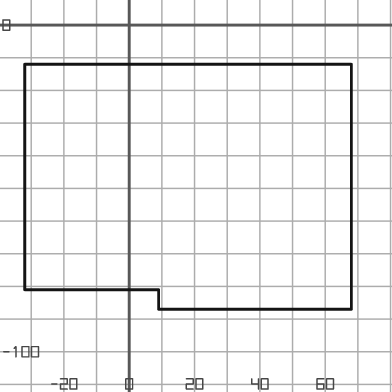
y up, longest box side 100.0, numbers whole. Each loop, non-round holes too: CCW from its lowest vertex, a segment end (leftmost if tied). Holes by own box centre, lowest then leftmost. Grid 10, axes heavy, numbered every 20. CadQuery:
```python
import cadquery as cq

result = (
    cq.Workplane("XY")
    .moveTo(9.0, -87.0)
    .lineTo(68.0, -87.0)
    .lineTo(68.0, -12.0)
    .lineTo(-32.0, -12.0)
    .lineTo(-32.0, -81.0)
    .lineTo(9.0, -81.0)
    .close()
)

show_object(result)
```